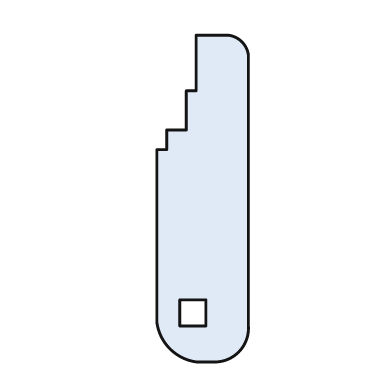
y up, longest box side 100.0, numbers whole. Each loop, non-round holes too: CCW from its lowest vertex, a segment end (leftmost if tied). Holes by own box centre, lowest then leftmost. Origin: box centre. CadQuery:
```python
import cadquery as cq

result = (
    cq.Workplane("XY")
    .moveTo(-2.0, -50.0)
    .lineTo(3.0, -50.0)
    .threePointArc((11.0, -47.0), (14.0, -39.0))
    .lineTo(14.0, 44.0)
    .threePointArc((12.0, 48.0), (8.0, 50.0))
    .lineTo(-2.0, 50.0)
    .lineTo(-2.0, 33.0)
    .lineTo(-5.0, 33.0)
    .lineTo(-5.0, 21.0)
    .lineTo(-11.0, 21.0)
    .lineTo(-11.0, 15.0)
    .lineTo(-14.0, 15.0)
    .lineTo(-14.0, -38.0)
    .threePointArc((-10.0, -46.0), (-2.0, -50.0))
    .close()
    .moveTo(-7.0, -39.0)
    .lineTo(1.0, -39.0)
    .lineTo(1.0, -31.0)
    .lineTo(-7.0, -31.0)
    .close()
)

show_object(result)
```